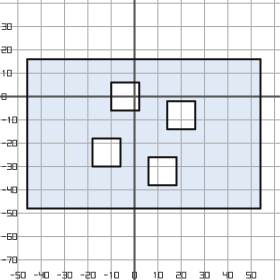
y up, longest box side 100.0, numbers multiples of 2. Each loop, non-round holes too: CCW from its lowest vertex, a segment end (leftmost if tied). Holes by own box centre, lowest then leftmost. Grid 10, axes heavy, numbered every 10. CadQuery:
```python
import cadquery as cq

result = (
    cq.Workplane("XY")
    .moveTo(-46.0, -48.0)
    .lineTo(54.0, -48.0)
    .lineTo(54.0, 16.0)
    .lineTo(-46.0, 16.0)
    .close()
    .moveTo(6.0, -38.0)
    .lineTo(18.0, -38.0)
    .lineTo(18.0, -26.0)
    .lineTo(6.0, -26.0)
    .close()
    .moveTo(-18.0, -30.0)
    .lineTo(-6.0, -30.0)
    .lineTo(-6.0, -18.0)
    .lineTo(-18.0, -18.0)
    .close()
    .moveTo(14.0, -14.0)
    .lineTo(26.0, -14.0)
    .lineTo(26.0, -2.0)
    .lineTo(14.0, -2.0)
    .close()
    .moveTo(-10.0, -6.0)
    .lineTo(2.0, -6.0)
    .lineTo(2.0, 6.0)
    .lineTo(-10.0, 6.0)
    .close()
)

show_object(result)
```